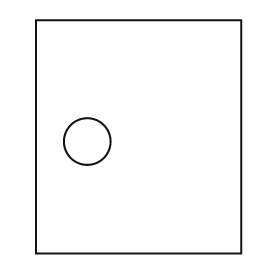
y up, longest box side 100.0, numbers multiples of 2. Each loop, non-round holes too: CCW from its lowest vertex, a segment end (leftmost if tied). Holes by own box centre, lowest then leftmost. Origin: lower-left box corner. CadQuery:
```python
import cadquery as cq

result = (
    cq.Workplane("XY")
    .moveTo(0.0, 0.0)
    .lineTo(88.0, 0.0)
    .lineTo(88.0, 100.0)
    .lineTo(0.0, 100.0)
    .close()
    .moveTo(22.0, 48.0)
    .circle(10.0)
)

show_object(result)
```